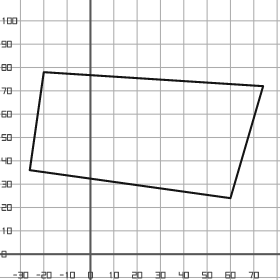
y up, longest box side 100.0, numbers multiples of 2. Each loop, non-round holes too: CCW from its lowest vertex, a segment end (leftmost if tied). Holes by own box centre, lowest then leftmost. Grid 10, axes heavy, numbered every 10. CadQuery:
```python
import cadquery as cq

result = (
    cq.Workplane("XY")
    .moveTo(60.0, 24.0)
    .lineTo(74.0, 72.0)
    .lineTo(-20.0, 78.0)
    .lineTo(-26.0, 36.0)
    .close()
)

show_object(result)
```